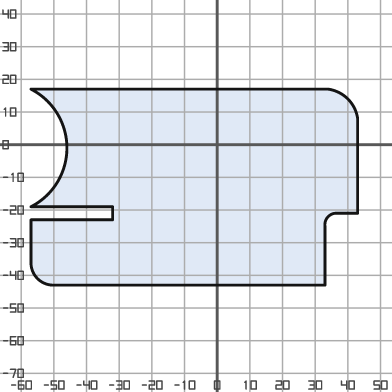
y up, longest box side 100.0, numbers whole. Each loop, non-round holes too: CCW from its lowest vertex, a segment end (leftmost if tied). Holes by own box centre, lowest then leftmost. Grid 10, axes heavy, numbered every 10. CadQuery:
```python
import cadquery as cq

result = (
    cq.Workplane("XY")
    .moveTo(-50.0, -43.0)
    .lineTo(33.0, -43.0)
    .lineTo(33.0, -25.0)
    .threePointArc((34.0, -22.0), (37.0, -21.0))
    .lineTo(43.0, -21.0)
    .lineTo(43.0, 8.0)
    .threePointArc((40.0, 14.0), (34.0, 17.0))
    .lineTo(-57.0, 17.0)
    .threePointArc((-46.0, -1.0), (-57.0, -19.0))
    .lineTo(-32.0, -19.0)
    .lineTo(-32.0, -23.0)
    .lineTo(-57.0, -23.0)
    .lineTo(-57.0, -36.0)
    .threePointArc((-55.0, -41.0), (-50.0, -43.0))
    .close()
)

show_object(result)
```